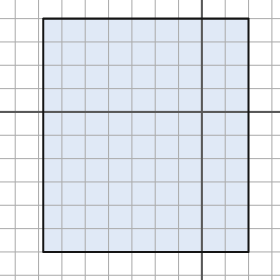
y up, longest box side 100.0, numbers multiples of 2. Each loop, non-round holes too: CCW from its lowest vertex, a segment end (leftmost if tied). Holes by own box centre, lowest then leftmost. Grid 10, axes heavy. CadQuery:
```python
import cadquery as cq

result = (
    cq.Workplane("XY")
    .moveTo(-68.0, -60.0)
    .lineTo(20.0, -60.0)
    .lineTo(20.0, 40.0)
    .lineTo(-68.0, 40.0)
    .close()
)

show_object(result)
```